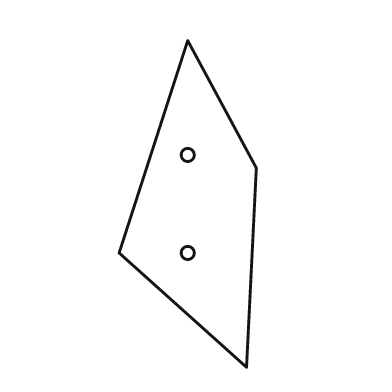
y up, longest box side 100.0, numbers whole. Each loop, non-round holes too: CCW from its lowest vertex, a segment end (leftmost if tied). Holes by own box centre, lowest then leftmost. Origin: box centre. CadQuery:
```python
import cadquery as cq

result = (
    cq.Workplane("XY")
    .moveTo(18.0, -50.0)
    .lineTo(21.0, 11.0)
    .lineTo(0.0, 50.0)
    .lineTo(-21.0, -15.0)
    .close()
    .moveTo(0.0, -15.0)
    .circle(2.0)
    .moveTo(0.0, 15.0)
    .circle(2.0)
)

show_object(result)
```